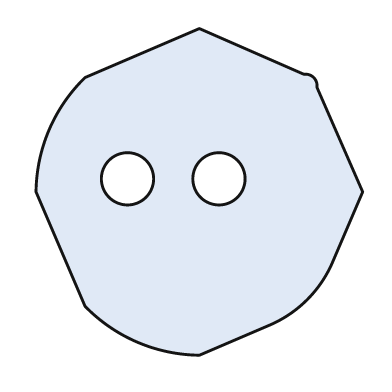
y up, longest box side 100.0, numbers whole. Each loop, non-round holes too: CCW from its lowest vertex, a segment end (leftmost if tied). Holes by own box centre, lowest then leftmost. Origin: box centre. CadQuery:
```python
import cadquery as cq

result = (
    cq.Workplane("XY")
    .moveTo(0.0, -50.0)
    .lineTo(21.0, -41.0)
    .threePointArc((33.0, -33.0), (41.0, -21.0))
    .lineTo(50.0, 0.0)
    .lineTo(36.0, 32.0)
    .threePointArc((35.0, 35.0), (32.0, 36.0))
    .lineTo(0.0, 50.0)
    .lineTo(-35.0, 35.0)
    .threePointArc((-46.0, 19.0), (-50.0, 0.0))
    .lineTo(-35.0, -35.0)
    .threePointArc((-19.0, -46.0), (0.0, -50.0))
    .close()
    .moveTo(-22.0, 4.0)
    .circle(8.0)
    .moveTo(6.0, 4.0)
    .circle(8.0)
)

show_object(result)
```